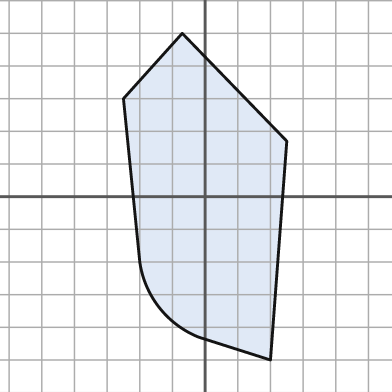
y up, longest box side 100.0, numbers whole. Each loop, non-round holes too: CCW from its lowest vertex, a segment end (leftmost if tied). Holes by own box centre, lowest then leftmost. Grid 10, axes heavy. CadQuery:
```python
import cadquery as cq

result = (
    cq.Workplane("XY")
    .moveTo(20.0, -50.0)
    .lineTo(25.0, 17.0)
    .lineTo(-7.0, 50.0)
    .lineTo(-25.0, 30.0)
    .lineTo(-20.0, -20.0)
    .threePointArc((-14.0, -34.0), (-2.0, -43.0))
    .close()
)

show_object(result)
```